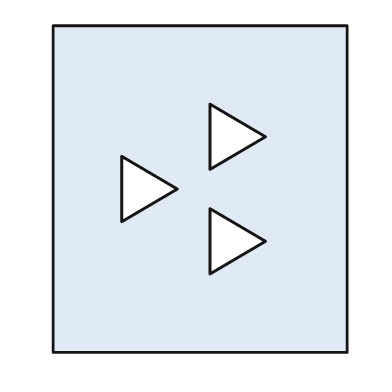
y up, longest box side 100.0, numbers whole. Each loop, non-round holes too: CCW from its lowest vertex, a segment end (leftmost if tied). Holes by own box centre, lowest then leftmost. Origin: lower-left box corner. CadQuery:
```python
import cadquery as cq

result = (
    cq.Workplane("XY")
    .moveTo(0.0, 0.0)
    .lineTo(90.0, 0.0)
    .lineTo(90.0, 100.0)
    .lineTo(0.0, 100.0)
    .close()
    .moveTo(48.0, 24.0)
    .lineTo(65.0, 34.0)
    .lineTo(48.0, 44.0)
    .close()
    .moveTo(21.0, 40.0)
    .lineTo(38.0, 50.0)
    .lineTo(21.0, 60.0)
    .close()
    .moveTo(48.0, 56.0)
    .lineTo(65.0, 66.0)
    .lineTo(48.0, 76.0)
    .close()
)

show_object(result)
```